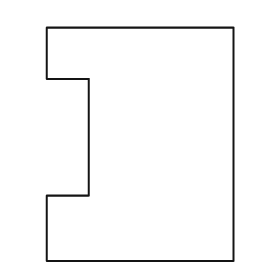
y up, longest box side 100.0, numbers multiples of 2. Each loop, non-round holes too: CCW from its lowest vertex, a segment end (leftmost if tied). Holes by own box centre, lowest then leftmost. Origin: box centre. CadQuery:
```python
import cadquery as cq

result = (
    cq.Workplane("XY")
    .moveTo(-40.0, -50.0)
    .lineTo(40.0, -50.0)
    .lineTo(40.0, 50.0)
    .lineTo(-40.0, 50.0)
    .lineTo(-40.0, 28.0)
    .lineTo(-22.0, 28.0)
    .lineTo(-22.0, -22.0)
    .lineTo(-40.0, -22.0)
    .close()
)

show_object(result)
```